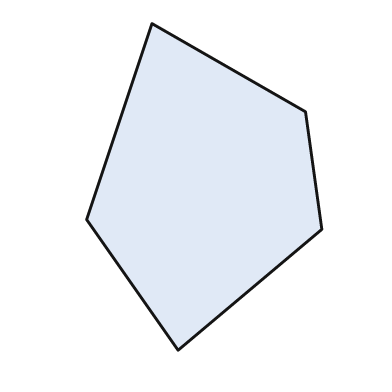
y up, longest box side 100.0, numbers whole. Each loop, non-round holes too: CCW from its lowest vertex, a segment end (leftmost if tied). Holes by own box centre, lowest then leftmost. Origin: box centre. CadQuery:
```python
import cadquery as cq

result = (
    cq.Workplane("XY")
    .moveTo(-8.0, -50.0)
    .lineTo(36.0, -13.0)
    .lineTo(31.0, 23.0)
    .lineTo(-16.0, 50.0)
    .lineTo(-36.0, -10.0)
    .close()
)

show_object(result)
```